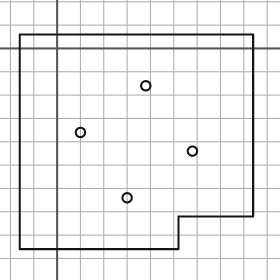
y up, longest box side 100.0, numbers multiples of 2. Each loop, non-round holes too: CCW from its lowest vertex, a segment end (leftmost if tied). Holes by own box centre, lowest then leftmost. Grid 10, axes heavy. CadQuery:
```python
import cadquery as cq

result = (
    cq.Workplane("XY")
    .moveTo(-16.0, -86.0)
    .lineTo(52.0, -86.0)
    .lineTo(52.0, -72.0)
    .lineTo(84.0, -72.0)
    .lineTo(84.0, 6.0)
    .lineTo(-16.0, 6.0)
    .close()
    .moveTo(30.0, -64.0)
    .circle(2.0)
    .moveTo(58.0, -44.0)
    .circle(2.0)
    .moveTo(10.0, -36.0)
    .circle(2.0)
    .moveTo(38.0, -16.0)
    .circle(2.0)
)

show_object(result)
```